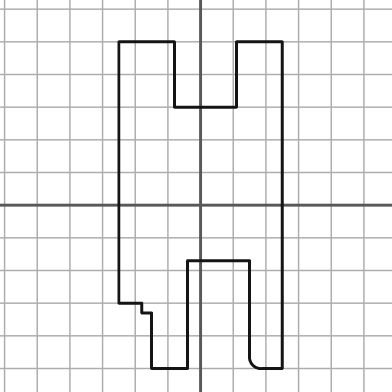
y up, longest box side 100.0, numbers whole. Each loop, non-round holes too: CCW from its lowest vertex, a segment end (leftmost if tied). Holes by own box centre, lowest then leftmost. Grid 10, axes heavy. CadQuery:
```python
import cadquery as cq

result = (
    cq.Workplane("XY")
    .moveTo(-15.0, -50.0)
    .lineTo(-4.0, -50.0)
    .lineTo(-4.0, -17.0)
    .lineTo(15.0, -17.0)
    .lineTo(15.0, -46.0)
    .threePointArc((16.0, -49.0), (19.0, -50.0))
    .lineTo(25.0, -50.0)
    .lineTo(25.0, 50.0)
    .lineTo(11.0, 50.0)
    .lineTo(11.0, 30.0)
    .lineTo(-8.0, 30.0)
    .lineTo(-8.0, 50.0)
    .lineTo(-25.0, 50.0)
    .lineTo(-25.0, -30.0)
    .lineTo(-18.0, -30.0)
    .lineTo(-18.0, -33.0)
    .lineTo(-15.0, -33.0)
    .close()
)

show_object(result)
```